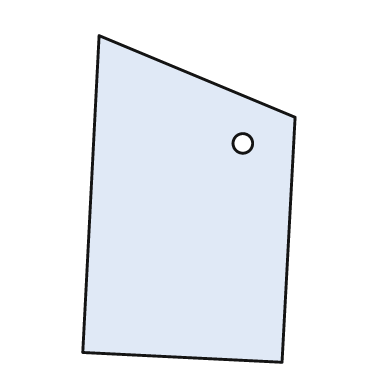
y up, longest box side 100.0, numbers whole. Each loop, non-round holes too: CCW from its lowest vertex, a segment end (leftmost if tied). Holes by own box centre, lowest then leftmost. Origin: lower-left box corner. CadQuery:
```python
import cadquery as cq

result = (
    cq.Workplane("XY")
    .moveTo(61.0, 0.0)
    .lineTo(65.0, 75.0)
    .lineTo(5.0, 100.0)
    .lineTo(0.0, 3.0)
    .close()
    .moveTo(49.0, 67.0)
    .circle(3.0)
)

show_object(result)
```